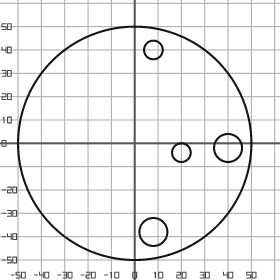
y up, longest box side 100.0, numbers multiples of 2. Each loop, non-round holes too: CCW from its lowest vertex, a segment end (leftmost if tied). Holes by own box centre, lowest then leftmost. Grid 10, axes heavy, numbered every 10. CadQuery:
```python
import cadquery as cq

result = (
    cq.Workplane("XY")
    .moveTo(0.0, 0.0)
    .circle(50.0)
    .moveTo(8.0, -38.0)
    .circle(6.0)
    .moveTo(20.0, -4.0)
    .circle(4.0)
    .moveTo(40.0, -2.0)
    .circle(6.0)
    .moveTo(8.0, 40.0)
    .circle(4.0)
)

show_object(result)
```